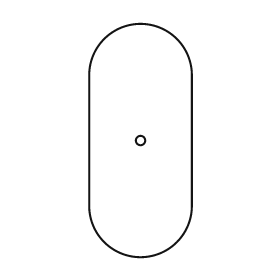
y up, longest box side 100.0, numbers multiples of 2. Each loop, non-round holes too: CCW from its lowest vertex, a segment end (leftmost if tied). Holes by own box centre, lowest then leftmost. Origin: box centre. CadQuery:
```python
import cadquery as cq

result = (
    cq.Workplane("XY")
    .moveTo(-22.0, -28.0)
    .threePointArc((0.0, -50.0), (22.0, -28.0))
    .lineTo(22.0, 28.0)
    .threePointArc((0.0, 50.0), (-22.0, 28.0))
    .close()
    .moveTo(0.0, 0.0)
    .circle(2.0)
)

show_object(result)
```